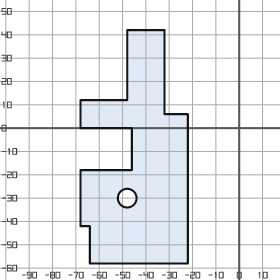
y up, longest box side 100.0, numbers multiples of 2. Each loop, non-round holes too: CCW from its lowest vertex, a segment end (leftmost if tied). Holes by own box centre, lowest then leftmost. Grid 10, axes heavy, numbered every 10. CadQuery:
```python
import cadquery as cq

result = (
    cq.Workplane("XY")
    .moveTo(-64.0, -58.0)
    .lineTo(-22.0, -58.0)
    .lineTo(-22.0, 6.0)
    .lineTo(-32.0, 6.0)
    .lineTo(-32.0, 42.0)
    .lineTo(-48.0, 42.0)
    .lineTo(-48.0, 12.0)
    .lineTo(-68.0, 12.0)
    .lineTo(-68.0, 0.0)
    .lineTo(-46.0, 0.0)
    .lineTo(-46.0, -18.0)
    .lineTo(-68.0, -18.0)
    .lineTo(-68.0, -42.0)
    .lineTo(-64.0, -42.0)
    .close()
    .moveTo(-48.0, -30.0)
    .circle(4.0)
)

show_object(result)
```